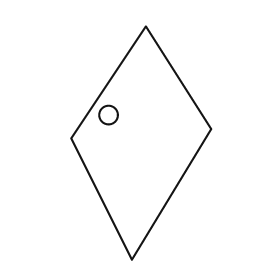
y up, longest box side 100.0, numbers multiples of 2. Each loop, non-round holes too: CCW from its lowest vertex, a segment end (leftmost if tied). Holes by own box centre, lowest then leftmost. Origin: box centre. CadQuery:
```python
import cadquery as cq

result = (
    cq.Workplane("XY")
    .moveTo(-4.0, -50.0)
    .lineTo(30.0, 6.0)
    .lineTo(2.0, 50.0)
    .lineTo(-30.0, 2.0)
    .close()
    .moveTo(-14.0, 12.0)
    .circle(4.0)
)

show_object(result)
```